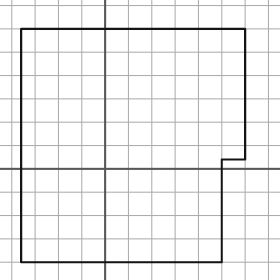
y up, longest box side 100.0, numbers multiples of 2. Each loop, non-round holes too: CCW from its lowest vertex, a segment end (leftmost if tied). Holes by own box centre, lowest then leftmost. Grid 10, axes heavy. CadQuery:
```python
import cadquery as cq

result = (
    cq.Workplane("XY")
    .moveTo(-36.0, -40.0)
    .lineTo(50.0, -40.0)
    .lineTo(50.0, 4.0)
    .lineTo(60.0, 4.0)
    .lineTo(60.0, 60.0)
    .lineTo(-36.0, 60.0)
    .close()
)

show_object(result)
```